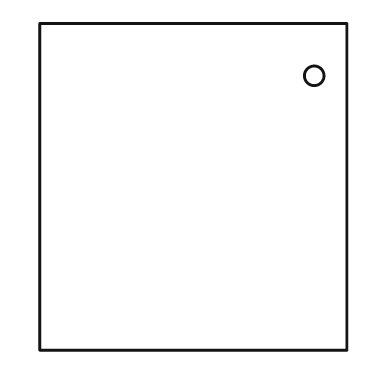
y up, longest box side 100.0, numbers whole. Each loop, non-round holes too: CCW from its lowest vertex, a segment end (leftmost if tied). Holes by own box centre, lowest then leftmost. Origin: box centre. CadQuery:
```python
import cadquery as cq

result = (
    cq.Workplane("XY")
    .moveTo(-47.0, -50.0)
    .lineTo(47.0, -50.0)
    .lineTo(47.0, 50.0)
    .lineTo(-47.0, 50.0)
    .close()
    .moveTo(37.0, 34.0)
    .circle(3.0)
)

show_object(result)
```